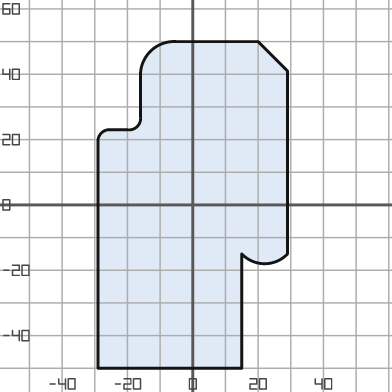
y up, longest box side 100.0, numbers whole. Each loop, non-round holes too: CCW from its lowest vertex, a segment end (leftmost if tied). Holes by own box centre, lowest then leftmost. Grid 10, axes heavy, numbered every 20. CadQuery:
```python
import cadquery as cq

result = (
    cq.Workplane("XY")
    .moveTo(-29.0, -50.0)
    .lineTo(15.0, -50.0)
    .lineTo(15.0, -15.0)
    .threePointArc((22.0, -18.0), (29.0, -15.0))
    .lineTo(29.0, 41.0)
    .lineTo(20.0, 50.0)
    .lineTo(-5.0, 50.0)
    .threePointArc((-13.0, 47.0), (-16.0, 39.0))
    .lineTo(-16.0, 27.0)
    .threePointArc((-17.0, 24.0), (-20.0, 23.0))
    .lineTo(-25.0, 23.0)
    .threePointArc((-28.0, 22.0), (-29.0, 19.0))
    .close()
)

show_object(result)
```